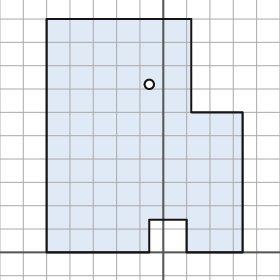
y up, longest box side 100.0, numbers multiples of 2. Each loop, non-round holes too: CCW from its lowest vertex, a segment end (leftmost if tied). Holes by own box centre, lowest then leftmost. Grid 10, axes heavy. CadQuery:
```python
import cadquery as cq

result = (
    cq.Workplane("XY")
    .moveTo(-50.0, 0.0)
    .lineTo(-6.0, 0.0)
    .lineTo(-6.0, 14.0)
    .lineTo(10.0, 14.0)
    .lineTo(10.0, 0.0)
    .lineTo(34.0, 0.0)
    .lineTo(34.0, 60.0)
    .lineTo(12.0, 60.0)
    .lineTo(12.0, 100.0)
    .lineTo(-50.0, 100.0)
    .close()
    .moveTo(-6.0, 72.0)
    .circle(2.0)
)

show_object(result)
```